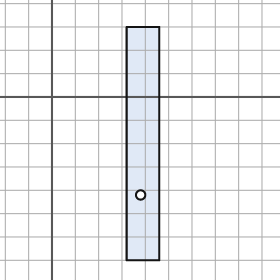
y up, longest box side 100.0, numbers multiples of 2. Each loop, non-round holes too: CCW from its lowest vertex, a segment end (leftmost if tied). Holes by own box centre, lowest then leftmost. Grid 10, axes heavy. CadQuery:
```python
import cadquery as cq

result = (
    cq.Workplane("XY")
    .moveTo(32.0, -70.0)
    .lineTo(46.0, -70.0)
    .lineTo(46.0, 30.0)
    .lineTo(32.0, 30.0)
    .close()
    .moveTo(38.0, -42.0)
    .circle(2.0)
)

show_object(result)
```